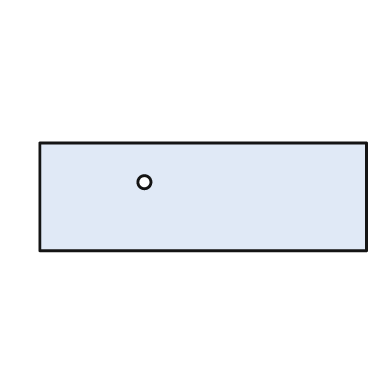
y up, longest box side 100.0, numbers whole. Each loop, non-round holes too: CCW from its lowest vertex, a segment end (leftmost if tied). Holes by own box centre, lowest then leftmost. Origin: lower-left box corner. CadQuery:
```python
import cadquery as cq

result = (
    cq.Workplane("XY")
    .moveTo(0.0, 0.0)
    .lineTo(100.0, 0.0)
    .lineTo(100.0, 33.0)
    .lineTo(0.0, 33.0)
    .close()
    .moveTo(32.0, 21.0)
    .circle(2.0)
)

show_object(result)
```